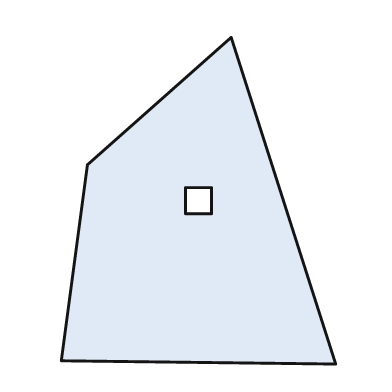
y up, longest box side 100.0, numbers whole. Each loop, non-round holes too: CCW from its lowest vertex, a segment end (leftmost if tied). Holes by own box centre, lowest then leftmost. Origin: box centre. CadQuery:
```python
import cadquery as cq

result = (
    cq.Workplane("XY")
    .moveTo(42.0, -50.0)
    .lineTo(10.0, 50.0)
    .lineTo(-34.0, 11.0)
    .lineTo(-42.0, -49.0)
    .close()
    .moveTo(-4.0, -4.0)
    .lineTo(4.0, -4.0)
    .lineTo(4.0, 4.0)
    .lineTo(-4.0, 4.0)
    .close()
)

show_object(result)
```